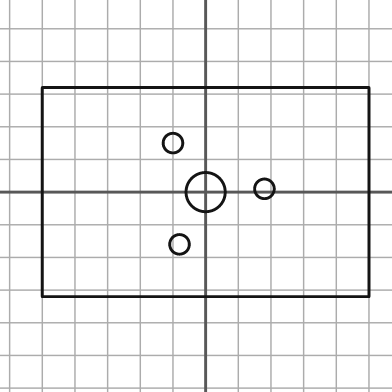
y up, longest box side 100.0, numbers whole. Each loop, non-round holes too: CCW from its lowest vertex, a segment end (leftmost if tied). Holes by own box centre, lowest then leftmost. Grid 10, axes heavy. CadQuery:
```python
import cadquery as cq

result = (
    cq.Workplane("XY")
    .moveTo(-50.0, -32.0)
    .lineTo(50.0, -32.0)
    .lineTo(50.0, 32.0)
    .lineTo(-50.0, 32.0)
    .close()
    .moveTo(-8.0, -16.0)
    .circle(3.0)
    .moveTo(0.0, 0.0)
    .circle(6.0)
    .moveTo(18.0, 1.0)
    .circle(3.0)
    .moveTo(-10.0, 15.0)
    .circle(3.0)
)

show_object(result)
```